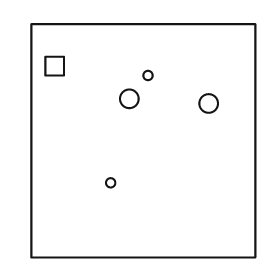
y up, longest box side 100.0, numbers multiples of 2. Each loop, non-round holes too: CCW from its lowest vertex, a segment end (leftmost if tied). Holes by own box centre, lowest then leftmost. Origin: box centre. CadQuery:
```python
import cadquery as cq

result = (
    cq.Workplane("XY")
    .moveTo(-48.0, -50.0)
    .lineTo(48.0, -50.0)
    .lineTo(48.0, 50.0)
    .lineTo(-48.0, 50.0)
    .close()
    .moveTo(-14.0, -18.0)
    .circle(2.0)
    .moveTo(28.0, 16.0)
    .circle(4.0)
    .moveTo(-6.0, 18.0)
    .circle(4.0)
    .moveTo(2.0, 28.0)
    .circle(2.0)
    .moveTo(-42.0, 28.0)
    .lineTo(-34.0, 28.0)
    .lineTo(-34.0, 36.0)
    .lineTo(-42.0, 36.0)
    .close()
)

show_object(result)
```